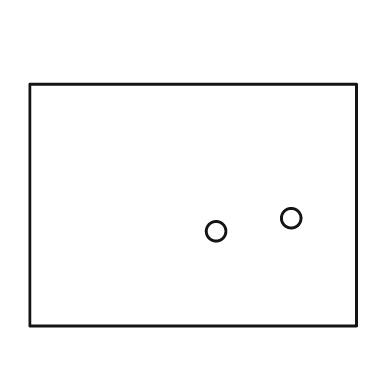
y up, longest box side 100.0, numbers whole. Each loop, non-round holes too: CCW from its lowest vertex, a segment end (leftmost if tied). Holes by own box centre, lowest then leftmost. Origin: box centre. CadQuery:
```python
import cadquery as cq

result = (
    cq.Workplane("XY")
    .moveTo(-50.0, -37.0)
    .lineTo(50.0, -37.0)
    .lineTo(50.0, 37.0)
    .lineTo(-50.0, 37.0)
    .close()
    .moveTo(7.0, -8.0)
    .circle(3.0)
    .moveTo(30.0, -4.0)
    .circle(3.0)
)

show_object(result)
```